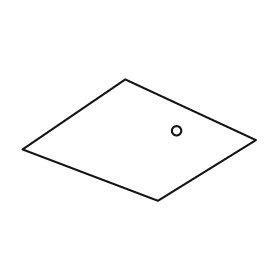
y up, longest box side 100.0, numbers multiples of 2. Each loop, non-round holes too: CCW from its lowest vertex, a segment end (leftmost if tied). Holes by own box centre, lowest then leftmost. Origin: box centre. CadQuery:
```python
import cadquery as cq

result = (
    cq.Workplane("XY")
    .moveTo(8.0, -26.0)
    .lineTo(50.0, 0.0)
    .lineTo(-6.0, 26.0)
    .lineTo(-50.0, -4.0)
    .close()
    .moveTo(16.0, 4.0)
    .circle(2.0)
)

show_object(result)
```